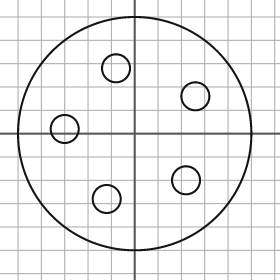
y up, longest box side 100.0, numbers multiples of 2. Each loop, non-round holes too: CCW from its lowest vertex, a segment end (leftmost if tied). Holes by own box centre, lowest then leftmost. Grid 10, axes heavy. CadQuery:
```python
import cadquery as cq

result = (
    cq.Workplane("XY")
    .moveTo(0.0, 0.0)
    .circle(50.0)
    .moveTo(-12.0, -28.0)
    .circle(6.0)
    .moveTo(22.0, -20.0)
    .circle(6.0)
    .moveTo(-30.0, 2.0)
    .circle(6.0)
    .moveTo(26.0, 16.0)
    .circle(6.0)
    .moveTo(-8.0, 28.0)
    .circle(6.0)
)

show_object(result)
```